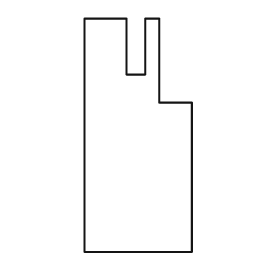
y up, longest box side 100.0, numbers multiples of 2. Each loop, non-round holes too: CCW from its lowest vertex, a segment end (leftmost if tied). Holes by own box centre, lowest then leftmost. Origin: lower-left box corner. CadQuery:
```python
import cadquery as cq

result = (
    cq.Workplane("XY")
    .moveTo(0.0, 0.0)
    .lineTo(46.0, 0.0)
    .lineTo(46.0, 64.0)
    .lineTo(32.0, 64.0)
    .lineTo(32.0, 100.0)
    .lineTo(26.0, 100.0)
    .lineTo(26.0, 76.0)
    .lineTo(18.0, 76.0)
    .lineTo(18.0, 100.0)
    .lineTo(0.0, 100.0)
    .close()
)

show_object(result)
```